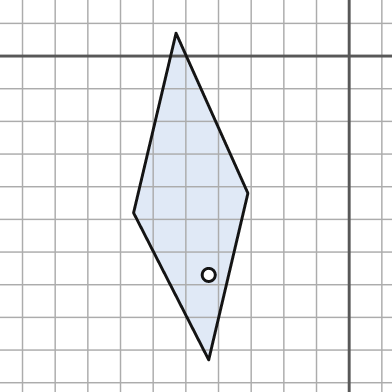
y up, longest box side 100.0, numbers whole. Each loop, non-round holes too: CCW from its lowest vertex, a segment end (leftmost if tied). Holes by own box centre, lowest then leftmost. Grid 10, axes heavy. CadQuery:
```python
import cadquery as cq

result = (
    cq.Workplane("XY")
    .moveTo(-43.0, -93.0)
    .lineTo(-31.0, -42.0)
    .lineTo(-53.0, 7.0)
    .lineTo(-66.0, -48.0)
    .close()
    .moveTo(-43.0, -67.0)
    .circle(2.0)
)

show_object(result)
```